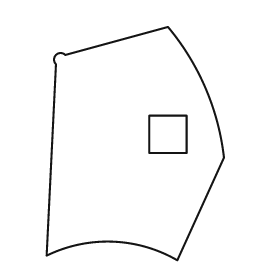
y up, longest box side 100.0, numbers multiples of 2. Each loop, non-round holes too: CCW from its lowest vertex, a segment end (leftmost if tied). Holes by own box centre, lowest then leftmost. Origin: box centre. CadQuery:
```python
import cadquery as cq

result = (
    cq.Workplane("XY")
    .moveTo(18.0, -50.0)
    .lineTo(38.0, -6.0)
    .threePointArc((30.0, 24.0), (14.0, 50.0))
    .lineTo(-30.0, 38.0)
    .threePointArc((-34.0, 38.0), (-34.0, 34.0))
    .lineTo(-38.0, -48.0)
    .threePointArc((-10.0, -42.0), (18.0, -50.0))
    .close()
    .moveTo(6.0, -4.0)
    .lineTo(22.0, -4.0)
    .lineTo(22.0, 12.0)
    .lineTo(6.0, 12.0)
    .close()
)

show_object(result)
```